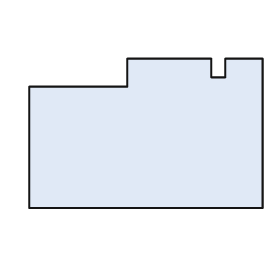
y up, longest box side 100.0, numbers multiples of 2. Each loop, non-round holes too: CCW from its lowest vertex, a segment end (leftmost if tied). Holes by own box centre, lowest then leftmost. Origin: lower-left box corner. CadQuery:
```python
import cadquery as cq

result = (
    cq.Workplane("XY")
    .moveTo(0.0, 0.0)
    .lineTo(100.0, 0.0)
    .lineTo(100.0, 64.0)
    .lineTo(84.0, 64.0)
    .lineTo(84.0, 56.0)
    .lineTo(78.0, 56.0)
    .lineTo(78.0, 64.0)
    .lineTo(42.0, 64.0)
    .lineTo(42.0, 52.0)
    .lineTo(0.0, 52.0)
    .close()
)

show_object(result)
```